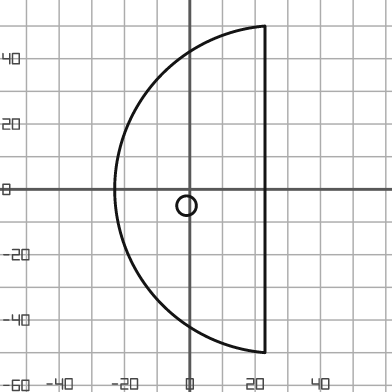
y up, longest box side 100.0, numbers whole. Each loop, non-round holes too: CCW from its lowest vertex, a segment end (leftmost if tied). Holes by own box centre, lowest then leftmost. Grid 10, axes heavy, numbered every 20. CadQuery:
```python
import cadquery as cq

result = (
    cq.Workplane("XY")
    .moveTo(23.0, -50.0)
    .lineTo(23.0, 50.0)
    .threePointArc((-23.0, 0.0), (23.0, -50.0))
    .close()
    .moveTo(-1.0, -5.0)
    .circle(3.0)
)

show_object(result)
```